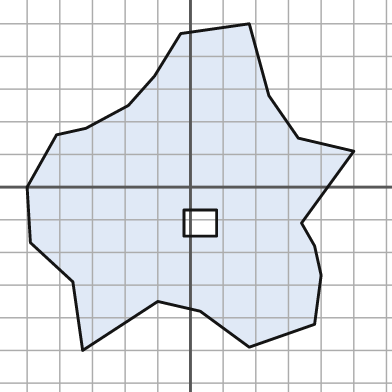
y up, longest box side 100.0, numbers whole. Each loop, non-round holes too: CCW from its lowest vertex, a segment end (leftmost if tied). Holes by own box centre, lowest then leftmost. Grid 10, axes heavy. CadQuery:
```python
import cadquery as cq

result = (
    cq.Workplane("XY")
    .moveTo(-33.0, -50.0)
    .lineTo(-10.0, -35.0)
    .lineTo(3.0, -38.0)
    .lineTo(18.0, -49.0)
    .lineTo(38.0, -42.0)
    .lineTo(40.0, -27.0)
    .lineTo(38.0, -18.0)
    .lineTo(34.0, -11.0)
    .lineTo(50.0, 11.0)
    .lineTo(33.0, 15.0)
    .lineTo(24.0, 28.0)
    .lineTo(18.0, 50.0)
    .lineTo(-3.0, 47.0)
    .lineTo(-11.0, 34.0)
    .lineTo(-19.0, 25.0)
    .lineTo(-32.0, 18.0)
    .lineTo(-41.0, 16.0)
    .lineTo(-50.0, 0.0)
    .lineTo(-49.0, -17.0)
    .lineTo(-36.0, -29.0)
    .close()
    .moveTo(-2.0, -15.0)
    .lineTo(8.0, -15.0)
    .lineTo(8.0, -7.0)
    .lineTo(-2.0, -7.0)
    .close()
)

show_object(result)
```